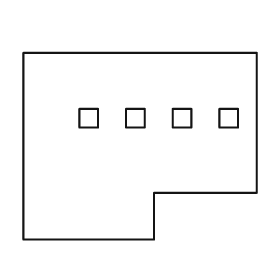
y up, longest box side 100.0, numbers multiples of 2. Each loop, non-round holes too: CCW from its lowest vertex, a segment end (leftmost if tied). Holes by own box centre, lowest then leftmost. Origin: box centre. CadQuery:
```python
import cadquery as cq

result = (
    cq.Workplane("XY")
    .moveTo(-50.0, -40.0)
    .lineTo(6.0, -40.0)
    .lineTo(6.0, -20.0)
    .lineTo(50.0, -20.0)
    .lineTo(50.0, 40.0)
    .lineTo(-50.0, 40.0)
    .close()
    .moveTo(-26.0, 8.0)
    .lineTo(-18.0, 8.0)
    .lineTo(-18.0, 16.0)
    .lineTo(-26.0, 16.0)
    .close()
    .moveTo(-6.0, 8.0)
    .lineTo(2.0, 8.0)
    .lineTo(2.0, 16.0)
    .lineTo(-6.0, 16.0)
    .close()
    .moveTo(14.0, 8.0)
    .lineTo(22.0, 8.0)
    .lineTo(22.0, 16.0)
    .lineTo(14.0, 16.0)
    .close()
    .moveTo(34.0, 8.0)
    .lineTo(42.0, 8.0)
    .lineTo(42.0, 16.0)
    .lineTo(34.0, 16.0)
    .close()
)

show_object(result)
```